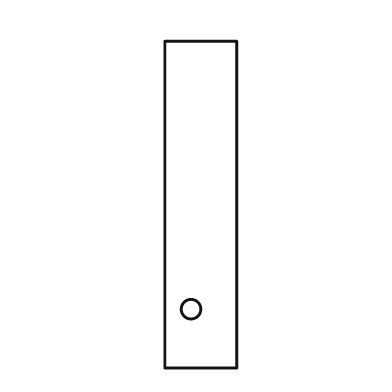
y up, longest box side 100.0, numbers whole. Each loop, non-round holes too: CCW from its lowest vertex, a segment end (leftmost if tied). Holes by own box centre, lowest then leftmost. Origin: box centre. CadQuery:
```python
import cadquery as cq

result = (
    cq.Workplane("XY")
    .moveTo(-11.0, -50.0)
    .lineTo(11.0, -50.0)
    .lineTo(11.0, 50.0)
    .lineTo(-11.0, 50.0)
    .close()
    .moveTo(-3.0, -32.0)
    .circle(3.0)
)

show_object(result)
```